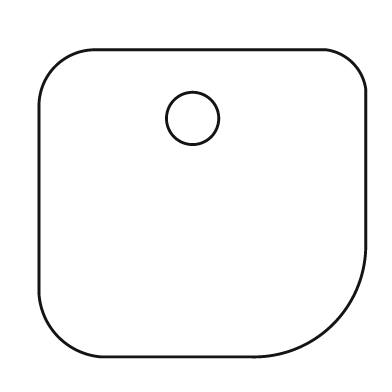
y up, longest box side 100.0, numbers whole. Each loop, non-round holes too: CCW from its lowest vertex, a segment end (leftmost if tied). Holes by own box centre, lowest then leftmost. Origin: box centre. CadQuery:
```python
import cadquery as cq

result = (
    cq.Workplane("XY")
    .moveTo(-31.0, -47.0)
    .lineTo(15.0, -47.0)
    .threePointArc((40.0, -37.0), (50.0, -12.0))
    .lineTo(50.0, 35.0)
    .threePointArc((46.0, 43.0), (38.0, 47.0))
    .lineTo(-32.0, 47.0)
    .threePointArc((-45.0, 42.0), (-50.0, 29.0))
    .lineTo(-50.0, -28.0)
    .threePointArc((-44.0, -41.0), (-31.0, -47.0))
    .close()
    .moveTo(-3.0, 26.0)
    .circle(8.0)
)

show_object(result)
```